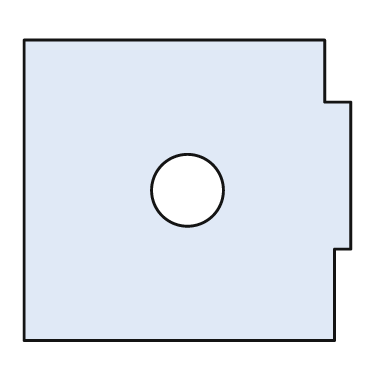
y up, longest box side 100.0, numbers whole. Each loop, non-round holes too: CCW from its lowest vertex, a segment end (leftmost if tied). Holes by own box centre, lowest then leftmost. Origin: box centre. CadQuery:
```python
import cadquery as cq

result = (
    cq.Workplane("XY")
    .moveTo(-50.0, -46.0)
    .lineTo(45.0, -46.0)
    .lineTo(45.0, -18.0)
    .lineTo(50.0, -18.0)
    .lineTo(50.0, 27.0)
    .lineTo(42.0, 27.0)
    .lineTo(42.0, 46.0)
    .lineTo(-50.0, 46.0)
    .close()
    .moveTo(0.0, 0.0)
    .circle(11.0)
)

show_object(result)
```